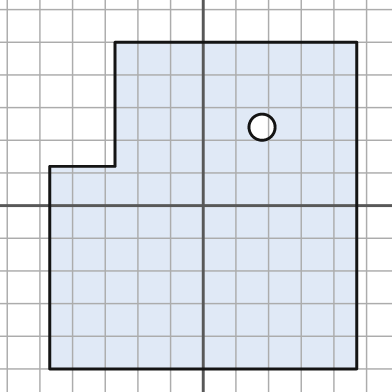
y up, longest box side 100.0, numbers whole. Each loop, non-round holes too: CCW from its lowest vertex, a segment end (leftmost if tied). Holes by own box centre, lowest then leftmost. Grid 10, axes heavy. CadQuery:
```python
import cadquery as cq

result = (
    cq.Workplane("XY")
    .moveTo(-47.0, -50.0)
    .lineTo(47.0, -50.0)
    .lineTo(47.0, 50.0)
    .lineTo(-27.0, 50.0)
    .lineTo(-27.0, 12.0)
    .lineTo(-47.0, 12.0)
    .close()
    .moveTo(18.0, 24.0)
    .circle(4.0)
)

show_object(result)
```